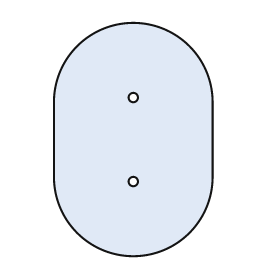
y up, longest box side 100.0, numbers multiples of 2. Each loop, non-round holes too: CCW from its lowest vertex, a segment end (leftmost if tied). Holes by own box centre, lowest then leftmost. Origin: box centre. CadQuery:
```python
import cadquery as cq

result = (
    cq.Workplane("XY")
    .moveTo(-34.0, -16.0)
    .threePointArc((0.0, -50.0), (34.0, -16.0))
    .lineTo(34.0, 16.0)
    .threePointArc((0.0, 50.0), (-34.0, 16.0))
    .close()
    .moveTo(0.0, -18.0)
    .circle(2.0)
    .moveTo(0.0, 18.0)
    .circle(2.0)
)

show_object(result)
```